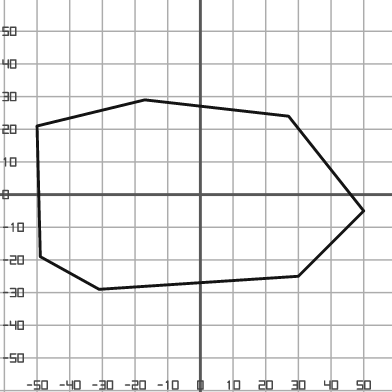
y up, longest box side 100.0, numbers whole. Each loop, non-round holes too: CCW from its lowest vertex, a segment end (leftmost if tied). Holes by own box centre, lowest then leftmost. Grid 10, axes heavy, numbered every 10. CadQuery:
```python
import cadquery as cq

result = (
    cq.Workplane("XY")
    .moveTo(-31.0, -29.0)
    .lineTo(30.0, -25.0)
    .lineTo(50.0, -5.0)
    .lineTo(27.0, 24.0)
    .lineTo(-17.0, 29.0)
    .lineTo(-50.0, 21.0)
    .lineTo(-49.0, -19.0)
    .close()
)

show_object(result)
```